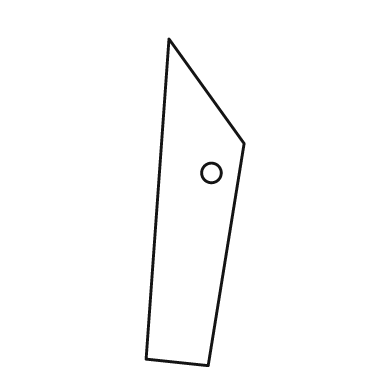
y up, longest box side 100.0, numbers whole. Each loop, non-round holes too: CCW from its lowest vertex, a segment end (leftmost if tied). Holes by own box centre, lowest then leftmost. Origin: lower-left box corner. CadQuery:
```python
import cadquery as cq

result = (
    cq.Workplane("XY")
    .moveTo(19.0, 0.0)
    .lineTo(30.0, 68.0)
    .lineTo(7.0, 100.0)
    .lineTo(0.0, 2.0)
    .close()
    .moveTo(20.0, 59.0)
    .circle(3.0)
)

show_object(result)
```